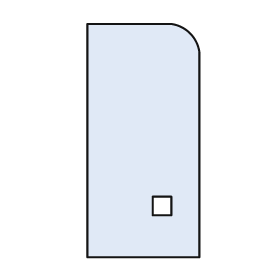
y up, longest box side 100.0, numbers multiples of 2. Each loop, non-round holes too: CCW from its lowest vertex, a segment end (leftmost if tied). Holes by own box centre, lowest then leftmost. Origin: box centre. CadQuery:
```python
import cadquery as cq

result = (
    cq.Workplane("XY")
    .moveTo(-24.0, -50.0)
    .lineTo(24.0, -50.0)
    .lineTo(24.0, 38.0)
    .threePointArc((20.0, 46.0), (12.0, 50.0))
    .lineTo(-24.0, 50.0)
    .close()
    .moveTo(4.0, -32.0)
    .lineTo(12.0, -32.0)
    .lineTo(12.0, -24.0)
    .lineTo(4.0, -24.0)
    .close()
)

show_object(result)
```